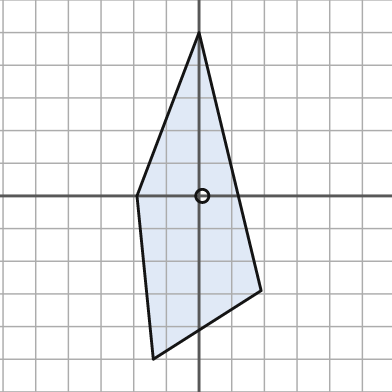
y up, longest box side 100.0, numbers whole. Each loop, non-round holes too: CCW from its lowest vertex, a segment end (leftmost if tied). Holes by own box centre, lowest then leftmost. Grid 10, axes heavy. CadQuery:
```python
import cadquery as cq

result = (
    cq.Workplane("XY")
    .moveTo(-14.0, -50.0)
    .lineTo(19.0, -29.0)
    .lineTo(0.0, 50.0)
    .lineTo(-19.0, 0.0)
    .close()
    .moveTo(1.0, 0.0)
    .circle(2.0)
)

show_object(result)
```